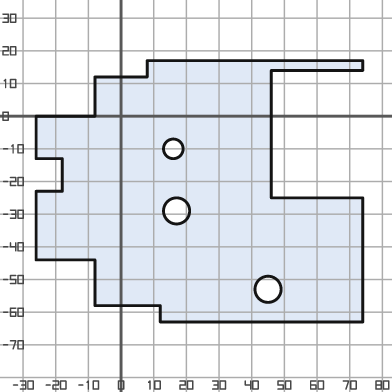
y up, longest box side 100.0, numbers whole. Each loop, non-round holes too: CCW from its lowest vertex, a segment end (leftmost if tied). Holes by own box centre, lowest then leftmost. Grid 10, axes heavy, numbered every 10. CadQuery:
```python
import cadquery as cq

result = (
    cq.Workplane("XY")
    .moveTo(12.0, -63.0)
    .lineTo(74.0, -63.0)
    .lineTo(74.0, -25.0)
    .lineTo(46.0, -25.0)
    .lineTo(46.0, 14.0)
    .lineTo(74.0, 14.0)
    .lineTo(74.0, 17.0)
    .lineTo(8.0, 17.0)
    .lineTo(8.0, 12.0)
    .lineTo(-8.0, 12.0)
    .lineTo(-8.0, 0.0)
    .lineTo(-26.0, 0.0)
    .lineTo(-26.0, -13.0)
    .lineTo(-18.0, -13.0)
    .lineTo(-18.0, -23.0)
    .lineTo(-26.0, -23.0)
    .lineTo(-26.0, -44.0)
    .lineTo(-8.0, -44.0)
    .lineTo(-8.0, -58.0)
    .lineTo(12.0, -58.0)
    .close()
    .moveTo(45.0, -53.0)
    .circle(4.0)
    .moveTo(17.0, -29.0)
    .circle(4.0)
    .moveTo(16.0, -10.0)
    .circle(3.0)
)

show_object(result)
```